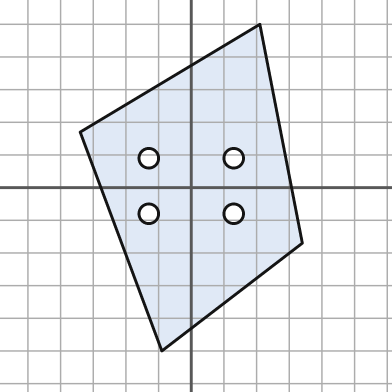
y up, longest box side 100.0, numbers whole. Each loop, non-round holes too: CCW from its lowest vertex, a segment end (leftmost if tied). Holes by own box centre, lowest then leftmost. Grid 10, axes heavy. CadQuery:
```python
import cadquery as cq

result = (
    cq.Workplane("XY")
    .moveTo(-9.0, -50.0)
    .lineTo(34.0, -17.0)
    .lineTo(21.0, 50.0)
    .lineTo(-34.0, 17.0)
    .close()
    .moveTo(-13.0, -8.0)
    .circle(3.0)
    .moveTo(13.0, -8.0)
    .circle(3.0)
    .moveTo(-13.0, 9.0)
    .circle(3.0)
    .moveTo(13.0, 9.0)
    .circle(3.0)
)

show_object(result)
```